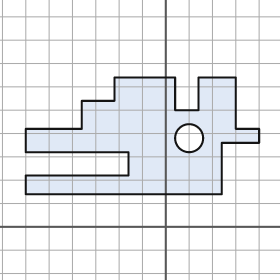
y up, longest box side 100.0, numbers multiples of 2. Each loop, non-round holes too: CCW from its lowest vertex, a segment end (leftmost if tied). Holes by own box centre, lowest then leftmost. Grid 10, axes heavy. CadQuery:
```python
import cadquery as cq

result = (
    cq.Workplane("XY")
    .moveTo(-60.0, 14.0)
    .lineTo(24.0, 14.0)
    .lineTo(24.0, 36.0)
    .lineTo(40.0, 36.0)
    .lineTo(40.0, 42.0)
    .lineTo(30.0, 42.0)
    .lineTo(30.0, 64.0)
    .lineTo(14.0, 64.0)
    .lineTo(14.0, 50.0)
    .lineTo(4.0, 50.0)
    .lineTo(4.0, 64.0)
    .lineTo(-22.0, 64.0)
    .lineTo(-22.0, 54.0)
    .lineTo(-36.0, 54.0)
    .lineTo(-36.0, 42.0)
    .lineTo(-60.0, 42.0)
    .lineTo(-60.0, 32.0)
    .lineTo(-16.0, 32.0)
    .lineTo(-16.0, 22.0)
    .lineTo(-60.0, 22.0)
    .close()
    .moveTo(10.0, 38.0)
    .circle(6.0)
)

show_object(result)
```